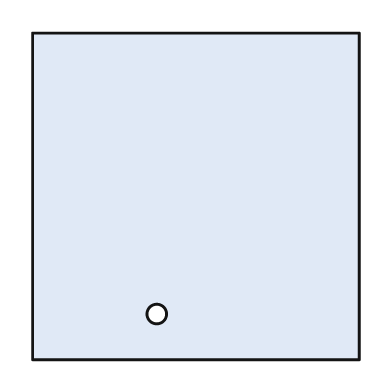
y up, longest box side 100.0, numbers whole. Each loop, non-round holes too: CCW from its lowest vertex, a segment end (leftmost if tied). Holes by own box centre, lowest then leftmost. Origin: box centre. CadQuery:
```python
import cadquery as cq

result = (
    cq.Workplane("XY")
    .moveTo(-50.0, -50.0)
    .lineTo(50.0, -50.0)
    .lineTo(50.0, 50.0)
    .lineTo(-50.0, 50.0)
    .close()
    .moveTo(-12.0, -36.0)
    .circle(3.0)
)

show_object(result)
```